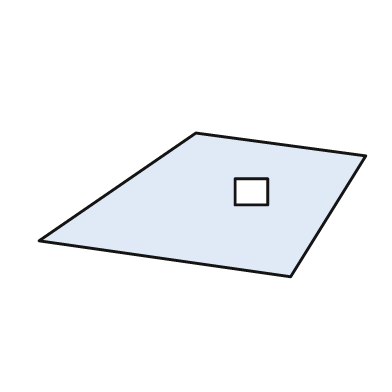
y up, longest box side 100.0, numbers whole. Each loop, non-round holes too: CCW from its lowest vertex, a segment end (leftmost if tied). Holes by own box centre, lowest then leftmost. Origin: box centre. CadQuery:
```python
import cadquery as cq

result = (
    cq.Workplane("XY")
    .moveTo(27.0, -22.0)
    .lineTo(50.0, 15.0)
    .lineTo(-2.0, 22.0)
    .lineTo(-50.0, -11.0)
    .close()
    .moveTo(10.0, 0.0)
    .lineTo(20.0, 0.0)
    .lineTo(20.0, 8.0)
    .lineTo(10.0, 8.0)
    .close()
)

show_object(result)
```